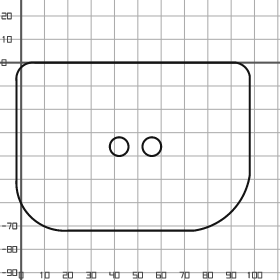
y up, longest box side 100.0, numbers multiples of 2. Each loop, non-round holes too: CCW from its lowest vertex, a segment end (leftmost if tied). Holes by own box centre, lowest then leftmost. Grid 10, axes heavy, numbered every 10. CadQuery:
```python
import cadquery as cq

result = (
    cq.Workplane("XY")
    .moveTo(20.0, -72.0)
    .lineTo(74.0, -72.0)
    .threePointArc((90.0, -64.0), (98.0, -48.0))
    .lineTo(98.0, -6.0)
    .threePointArc((96.0, -2.0), (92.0, 0.0))
    .lineTo(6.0, 0.0)
    .threePointArc((0.0, -2.0), (-2.0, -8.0))
    .lineTo(-2.0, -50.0)
    .threePointArc((4.0, -66.0), (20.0, -72.0))
    .close()
    .moveTo(42.0, -36.0)
    .circle(4.0)
    .moveTo(56.0, -36.0)
    .circle(4.0)
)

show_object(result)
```